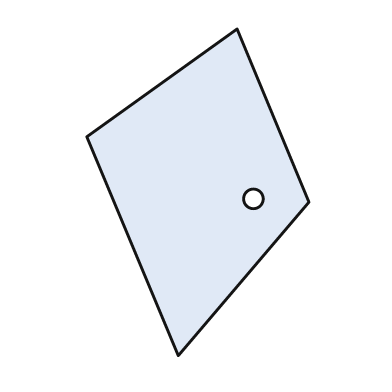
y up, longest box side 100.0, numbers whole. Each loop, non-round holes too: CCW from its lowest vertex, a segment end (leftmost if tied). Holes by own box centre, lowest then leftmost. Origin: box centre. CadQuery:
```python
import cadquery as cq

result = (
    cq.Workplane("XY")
    .moveTo(-6.0, -50.0)
    .lineTo(34.0, -3.0)
    .lineTo(12.0, 50.0)
    .lineTo(-34.0, 17.0)
    .close()
    .moveTo(17.0, -2.0)
    .circle(3.0)
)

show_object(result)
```